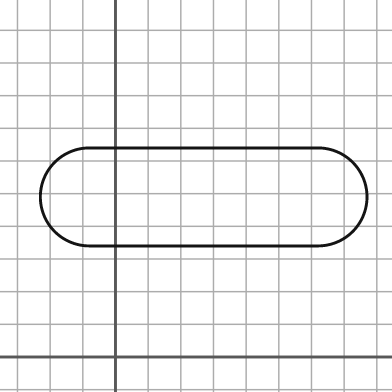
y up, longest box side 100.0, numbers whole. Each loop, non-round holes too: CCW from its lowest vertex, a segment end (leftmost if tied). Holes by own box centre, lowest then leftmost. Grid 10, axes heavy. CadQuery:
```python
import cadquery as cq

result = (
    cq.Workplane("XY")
    .moveTo(-8.0, 34.0)
    .lineTo(62.0, 34.0)
    .threePointArc((77.0, 49.0), (62.0, 64.0))
    .lineTo(-8.0, 64.0)
    .threePointArc((-23.0, 49.0), (-8.0, 34.0))
    .close()
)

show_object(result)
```